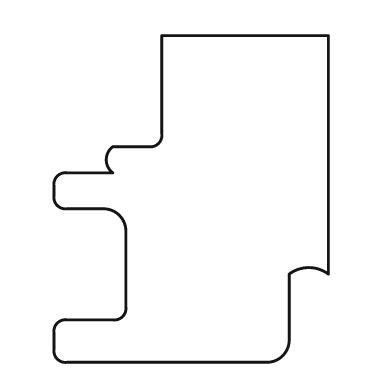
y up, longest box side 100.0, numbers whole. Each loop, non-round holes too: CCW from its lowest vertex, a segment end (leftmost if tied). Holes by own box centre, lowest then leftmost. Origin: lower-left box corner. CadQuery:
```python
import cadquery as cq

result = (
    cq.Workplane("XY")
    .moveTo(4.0, 0.0)
    .lineTo(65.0, 0.0)
    .threePointArc((70.0, 2.0), (72.0, 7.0))
    .lineTo(72.0, 27.0)
    .threePointArc((78.0, 29.0), (84.0, 27.0))
    .lineTo(84.0, 100.0)
    .lineTo(33.0, 100.0)
    .lineTo(33.0, 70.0)
    .threePointArc((32.0, 67.0), (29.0, 66.0))
    .lineTo(18.0, 66.0)
    .threePointArc((16.0, 62.0), (18.0, 58.0))
    .lineTo(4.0, 58.0)
    .threePointArc((1.0, 57.0), (0.0, 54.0))
    .lineTo(0.0, 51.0)
    .threePointArc((1.0, 48.0), (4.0, 47.0))
    .lineTo(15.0, 47.0)
    .threePointArc((20.0, 45.0), (22.0, 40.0))
    .lineTo(22.0, 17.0)
    .threePointArc((21.0, 14.0), (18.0, 13.0))
    .lineTo(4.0, 13.0)
    .threePointArc((1.0, 12.0), (0.0, 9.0))
    .lineTo(0.0, 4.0)
    .threePointArc((1.0, 1.0), (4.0, 0.0))
    .close()
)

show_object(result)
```